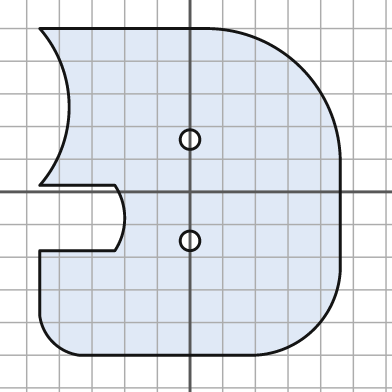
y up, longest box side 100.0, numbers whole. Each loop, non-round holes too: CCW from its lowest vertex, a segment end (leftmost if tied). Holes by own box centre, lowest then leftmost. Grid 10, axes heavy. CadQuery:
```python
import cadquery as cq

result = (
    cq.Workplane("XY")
    .moveTo(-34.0, -50.0)
    .lineTo(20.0, -50.0)
    .threePointArc((38.0, -42.0), (46.0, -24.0))
    .lineTo(46.0, 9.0)
    .threePointArc((34.0, 38.0), (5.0, 50.0))
    .lineTo(-46.0, 50.0)
    .threePointArc((-37.0, 26.0), (-46.0, 2.0))
    .lineTo(-23.0, 2.0)
    .threePointArc((-20.0, -8.0), (-23.0, -18.0))
    .lineTo(-46.0, -18.0)
    .lineTo(-46.0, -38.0)
    .threePointArc((-42.0, -46.0), (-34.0, -50.0))
    .close()
    .moveTo(0.0, -15.0)
    .circle(3.0)
    .moveTo(0.0, 16.0)
    .circle(3.0)
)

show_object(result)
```